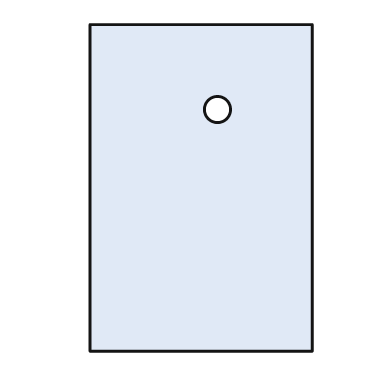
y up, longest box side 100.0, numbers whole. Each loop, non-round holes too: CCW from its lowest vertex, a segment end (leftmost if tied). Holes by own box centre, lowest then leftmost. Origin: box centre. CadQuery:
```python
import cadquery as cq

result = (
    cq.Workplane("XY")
    .moveTo(-34.0, -50.0)
    .lineTo(34.0, -50.0)
    .lineTo(34.0, 50.0)
    .lineTo(-34.0, 50.0)
    .close()
    .moveTo(5.0, 24.0)
    .circle(4.0)
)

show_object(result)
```